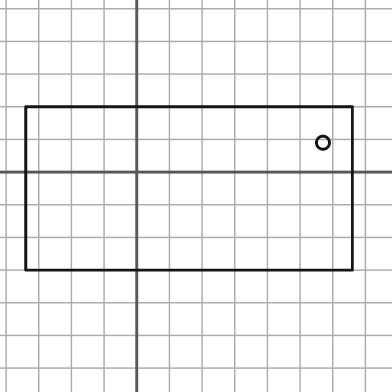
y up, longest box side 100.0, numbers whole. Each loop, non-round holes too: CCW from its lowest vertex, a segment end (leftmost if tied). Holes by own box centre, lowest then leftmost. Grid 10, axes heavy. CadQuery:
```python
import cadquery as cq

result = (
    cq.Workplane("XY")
    .moveTo(-34.0, -30.0)
    .lineTo(66.0, -30.0)
    .lineTo(66.0, 20.0)
    .lineTo(-34.0, 20.0)
    .close()
    .moveTo(57.0, 9.0)
    .circle(2.0)
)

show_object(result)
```